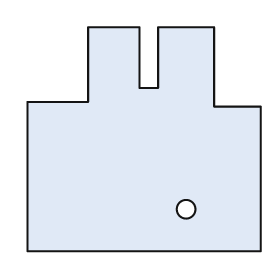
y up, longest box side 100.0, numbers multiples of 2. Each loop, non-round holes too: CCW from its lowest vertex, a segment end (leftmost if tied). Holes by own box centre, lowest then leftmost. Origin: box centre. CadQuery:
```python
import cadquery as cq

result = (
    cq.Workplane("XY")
    .moveTo(-50.0, -48.0)
    .lineTo(50.0, -48.0)
    .lineTo(50.0, 14.0)
    .lineTo(30.0, 14.0)
    .lineTo(30.0, 48.0)
    .lineTo(6.0, 48.0)
    .lineTo(6.0, 22.0)
    .lineTo(-2.0, 22.0)
    .lineTo(-2.0, 48.0)
    .lineTo(-24.0, 48.0)
    .lineTo(-24.0, 16.0)
    .lineTo(-50.0, 16.0)
    .close()
    .moveTo(18.0, -30.0)
    .circle(4.0)
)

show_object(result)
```